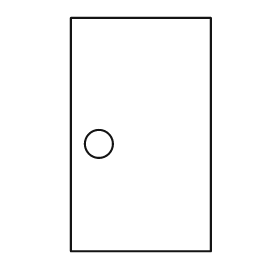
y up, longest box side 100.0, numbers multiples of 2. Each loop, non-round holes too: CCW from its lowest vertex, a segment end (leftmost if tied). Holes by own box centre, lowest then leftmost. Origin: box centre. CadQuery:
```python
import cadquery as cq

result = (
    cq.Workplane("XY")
    .moveTo(-30.0, -50.0)
    .lineTo(30.0, -50.0)
    .lineTo(30.0, 50.0)
    .lineTo(-30.0, 50.0)
    .close()
    .moveTo(-18.0, -4.0)
    .circle(6.0)
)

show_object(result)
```